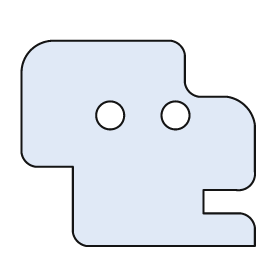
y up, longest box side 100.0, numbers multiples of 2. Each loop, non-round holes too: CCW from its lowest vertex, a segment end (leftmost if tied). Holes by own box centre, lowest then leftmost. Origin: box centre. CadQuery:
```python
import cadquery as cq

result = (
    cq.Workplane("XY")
    .moveTo(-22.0, -44.0)
    .lineTo(50.0, -44.0)
    .lineTo(50.0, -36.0)
    .threePointArc((48.0, -32.0), (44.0, -30.0))
    .lineTo(28.0, -30.0)
    .lineTo(28.0, -20.0)
    .lineTo(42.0, -20.0)
    .threePointArc((48.0, -18.0), (50.0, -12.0))
    .lineTo(50.0, 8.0)
    .threePointArc((46.0, 16.0), (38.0, 20.0))
    .lineTo(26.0, 20.0)
    .threePointArc((22.0, 22.0), (20.0, 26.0))
    .lineTo(20.0, 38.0)
    .threePointArc((18.0, 42.0), (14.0, 44.0))
    .lineTo(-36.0, 44.0)
    .threePointArc((-46.0, 40.0), (-50.0, 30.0))
    .lineTo(-50.0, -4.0)
    .threePointArc((-48.0, -8.0), (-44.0, -10.0))
    .lineTo(-28.0, -10.0)
    .lineTo(-28.0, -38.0)
    .threePointArc((-26.0, -42.0), (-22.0, -44.0))
    .close()
    .moveTo(-12.0, 12.0)
    .circle(6.0)
    .moveTo(16.0, 12.0)
    .circle(6.0)
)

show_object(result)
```